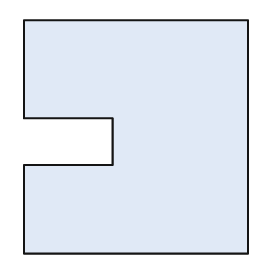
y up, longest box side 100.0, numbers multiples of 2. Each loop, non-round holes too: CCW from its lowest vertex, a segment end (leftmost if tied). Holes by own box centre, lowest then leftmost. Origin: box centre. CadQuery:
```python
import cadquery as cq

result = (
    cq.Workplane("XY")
    .moveTo(-48.0, -50.0)
    .lineTo(48.0, -50.0)
    .lineTo(48.0, 50.0)
    .lineTo(-48.0, 50.0)
    .lineTo(-48.0, 8.0)
    .lineTo(-10.0, 8.0)
    .lineTo(-10.0, -12.0)
    .lineTo(-48.0, -12.0)
    .close()
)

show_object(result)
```